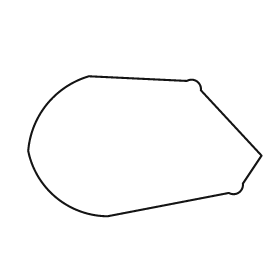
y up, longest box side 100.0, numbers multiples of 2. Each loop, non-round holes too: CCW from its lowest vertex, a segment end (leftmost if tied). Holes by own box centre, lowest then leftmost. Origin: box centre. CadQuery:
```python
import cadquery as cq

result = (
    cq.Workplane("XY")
    .moveTo(-16.0, -30.0)
    .lineTo(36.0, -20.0)
    .threePointArc((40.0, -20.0), (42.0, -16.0))
    .lineTo(50.0, -4.0)
    .lineTo(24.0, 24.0)
    .threePointArc((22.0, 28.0), (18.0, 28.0))
    .lineTo(-24.0, 30.0)
    .threePointArc((-42.0, 18.0), (-50.0, -2.0))
    .threePointArc((-38.0, -22.0), (-16.0, -30.0))
    .close()
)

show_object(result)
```